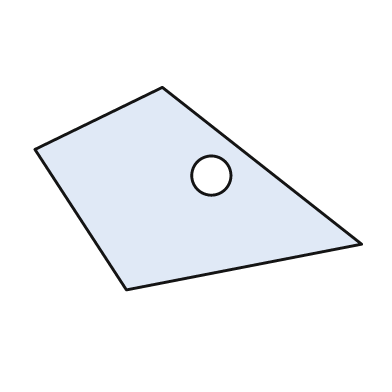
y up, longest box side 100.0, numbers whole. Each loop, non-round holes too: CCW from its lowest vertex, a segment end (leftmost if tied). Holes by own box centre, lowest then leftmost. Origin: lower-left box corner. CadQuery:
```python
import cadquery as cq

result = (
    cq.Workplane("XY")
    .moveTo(28.0, 0.0)
    .lineTo(100.0, 14.0)
    .lineTo(39.0, 62.0)
    .lineTo(0.0, 43.0)
    .close()
    .moveTo(54.0, 35.0)
    .circle(6.0)
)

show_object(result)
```